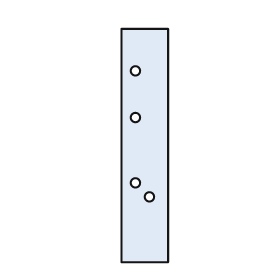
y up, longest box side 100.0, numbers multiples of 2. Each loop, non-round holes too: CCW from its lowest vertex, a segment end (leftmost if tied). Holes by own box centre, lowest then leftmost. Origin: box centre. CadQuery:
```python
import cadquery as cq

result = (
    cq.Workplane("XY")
    .moveTo(-10.0, -50.0)
    .lineTo(10.0, -50.0)
    .lineTo(10.0, 50.0)
    .lineTo(-10.0, 50.0)
    .close()
    .moveTo(2.0, -22.0)
    .circle(2.0)
    .moveTo(-4.0, -16.0)
    .circle(2.0)
    .moveTo(-4.0, 12.0)
    .circle(2.0)
    .moveTo(-4.0, 32.0)
    .circle(2.0)
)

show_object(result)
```